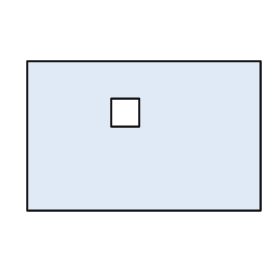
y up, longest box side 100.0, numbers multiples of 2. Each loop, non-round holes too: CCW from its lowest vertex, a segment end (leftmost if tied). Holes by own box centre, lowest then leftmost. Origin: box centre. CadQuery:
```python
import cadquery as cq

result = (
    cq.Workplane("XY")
    .moveTo(-50.0, -32.0)
    .lineTo(50.0, -32.0)
    .lineTo(50.0, 32.0)
    .lineTo(-50.0, 32.0)
    .close()
    .moveTo(-14.0, 4.0)
    .lineTo(-2.0, 4.0)
    .lineTo(-2.0, 16.0)
    .lineTo(-14.0, 16.0)
    .close()
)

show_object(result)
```